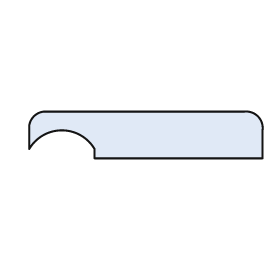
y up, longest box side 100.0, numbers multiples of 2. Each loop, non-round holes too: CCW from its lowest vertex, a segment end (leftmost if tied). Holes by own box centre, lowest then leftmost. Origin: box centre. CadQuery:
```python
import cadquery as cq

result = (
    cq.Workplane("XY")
    .moveTo(-22.0, -10.0)
    .lineTo(50.0, -10.0)
    .lineTo(50.0, 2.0)
    .threePointArc((48.0, 8.0), (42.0, 10.0))
    .lineTo(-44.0, 10.0)
    .threePointArc((-48.0, 8.0), (-50.0, 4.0))
    .lineTo(-50.0, -6.0)
    .threePointArc((-36.0, 2.0), (-22.0, -6.0))
    .close()
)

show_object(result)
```